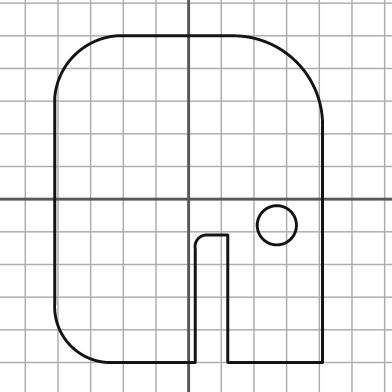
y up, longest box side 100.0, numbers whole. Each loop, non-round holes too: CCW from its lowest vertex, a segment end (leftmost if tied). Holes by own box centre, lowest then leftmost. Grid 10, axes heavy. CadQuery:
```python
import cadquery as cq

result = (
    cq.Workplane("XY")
    .moveTo(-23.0, -50.0)
    .lineTo(2.0, -50.0)
    .lineTo(2.0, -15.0)
    .threePointArc((3.0, -12.0), (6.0, -11.0))
    .lineTo(12.0, -11.0)
    .lineTo(12.0, -50.0)
    .lineTo(41.0, -50.0)
    .lineTo(41.0, 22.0)
    .threePointArc((33.0, 42.0), (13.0, 50.0))
    .lineTo(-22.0, 50.0)
    .threePointArc((-35.0, 44.0), (-41.0, 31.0))
    .lineTo(-41.0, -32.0)
    .threePointArc((-36.0, -45.0), (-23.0, -50.0))
    .close()
    .moveTo(27.0, -8.0)
    .circle(6.0)
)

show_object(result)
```